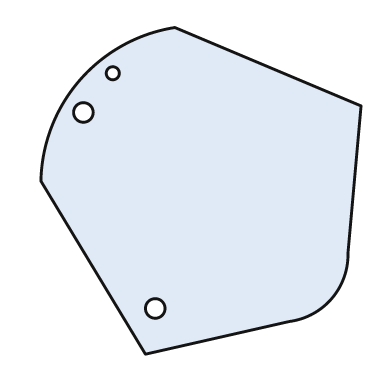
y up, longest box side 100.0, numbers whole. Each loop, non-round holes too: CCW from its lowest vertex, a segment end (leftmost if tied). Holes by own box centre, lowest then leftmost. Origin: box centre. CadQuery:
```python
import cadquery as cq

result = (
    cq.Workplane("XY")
    .moveTo(-17.0, -50.0)
    .lineTo(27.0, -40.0)
    .threePointArc((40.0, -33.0), (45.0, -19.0))
    .lineTo(49.0, 26.0)
    .lineTo(-8.0, 50.0)
    .threePointArc((-37.0, 34.0), (-49.0, 3.0))
    .close()
    .moveTo(-14.0, -36.0)
    .circle(3.0)
    .moveTo(-36.0, 24.0)
    .circle(3.0)
    .moveTo(-27.0, 36.0)
    .circle(2.0)
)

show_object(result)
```